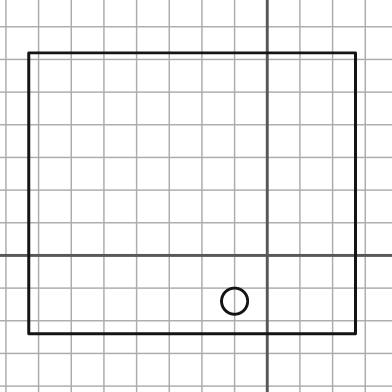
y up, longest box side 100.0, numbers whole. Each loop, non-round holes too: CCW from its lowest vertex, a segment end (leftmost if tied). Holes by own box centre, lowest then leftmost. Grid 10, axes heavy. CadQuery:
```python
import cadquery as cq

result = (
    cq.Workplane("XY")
    .moveTo(-73.0, -24.0)
    .lineTo(27.0, -24.0)
    .lineTo(27.0, 62.0)
    .lineTo(-73.0, 62.0)
    .close()
    .moveTo(-10.0, -14.0)
    .circle(4.0)
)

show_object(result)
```